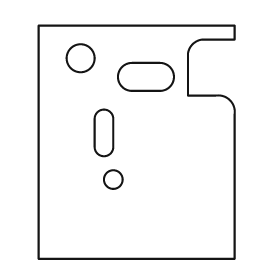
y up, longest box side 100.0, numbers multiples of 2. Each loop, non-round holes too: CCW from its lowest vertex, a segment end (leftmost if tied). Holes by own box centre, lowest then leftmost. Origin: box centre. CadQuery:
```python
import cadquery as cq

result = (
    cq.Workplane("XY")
    .moveTo(-42.0, -50.0)
    .lineTo(42.0, -50.0)
    .lineTo(42.0, 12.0)
    .threePointArc((40.0, 18.0), (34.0, 20.0))
    .lineTo(22.0, 20.0)
    .lineTo(22.0, 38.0)
    .threePointArc((24.0, 42.0), (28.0, 44.0))
    .lineTo(42.0, 44.0)
    .lineTo(42.0, 50.0)
    .lineTo(-42.0, 50.0)
    .close()
    .moveTo(-10.0, -16.0)
    .circle(4.0)
    .moveTo(-18.0, -2.0)
    .threePointArc((-14.0, -6.0), (-10.0, -2.0))
    .lineTo(-10.0, 10.0)
    .threePointArc((-14.0, 14.0), (-18.0, 10.0))
    .close()
    .moveTo(-2.0, 22.0)
    .lineTo(10.0, 22.0)
    .threePointArc((16.0, 28.0), (10.0, 34.0))
    .lineTo(-2.0, 34.0)
    .threePointArc((-8.0, 28.0), (-2.0, 22.0))
    .close()
    .moveTo(-24.0, 36.0)
    .circle(6.0)
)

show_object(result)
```